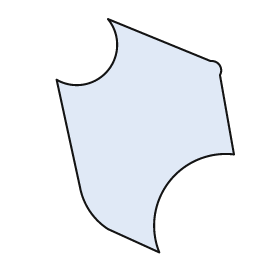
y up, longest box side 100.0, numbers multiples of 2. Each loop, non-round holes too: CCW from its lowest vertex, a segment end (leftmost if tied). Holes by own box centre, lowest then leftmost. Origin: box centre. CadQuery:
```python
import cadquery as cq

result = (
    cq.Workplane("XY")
    .moveTo(6.0, -50.0)
    .threePointArc((10.0, -20.0), (38.0, -8.0))
    .lineTo(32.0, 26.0)
    .threePointArc((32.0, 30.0), (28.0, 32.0))
    .lineTo(-16.0, 50.0)
    .threePointArc((-16.0, 28.0), (-38.0, 24.0))
    .lineTo(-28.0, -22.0)
    .threePointArc((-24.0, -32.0), (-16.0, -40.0))
    .close()
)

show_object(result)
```